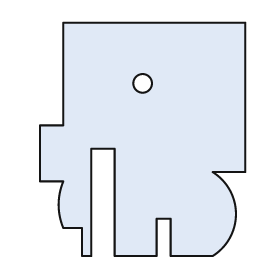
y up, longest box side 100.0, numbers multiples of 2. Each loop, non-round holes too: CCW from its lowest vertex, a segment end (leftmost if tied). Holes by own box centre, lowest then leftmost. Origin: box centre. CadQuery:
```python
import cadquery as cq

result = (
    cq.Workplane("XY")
    .moveTo(-26.0, -50.0)
    .lineTo(-22.0, -50.0)
    .lineTo(-22.0, -4.0)
    .lineTo(-12.0, -4.0)
    .lineTo(-12.0, -50.0)
    .lineTo(6.0, -50.0)
    .lineTo(6.0, -34.0)
    .lineTo(12.0, -34.0)
    .lineTo(12.0, -50.0)
    .lineTo(30.0, -50.0)
    .threePointArc((40.0, -32.0), (30.0, -14.0))
    .lineTo(44.0, -14.0)
    .lineTo(44.0, 50.0)
    .lineTo(-34.0, 50.0)
    .lineTo(-34.0, 6.0)
    .lineTo(-44.0, 6.0)
    .lineTo(-44.0, -18.0)
    .lineTo(-34.0, -18.0)
    .threePointArc((-36.0, -28.0), (-34.0, -38.0))
    .lineTo(-26.0, -38.0)
    .close()
    .moveTo(0.0, 24.0)
    .circle(4.0)
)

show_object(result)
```